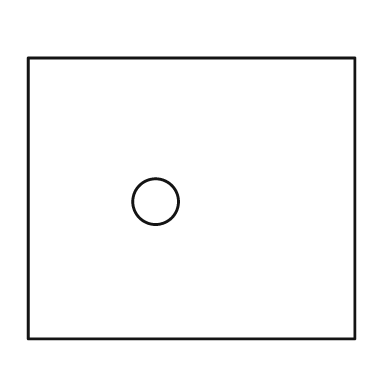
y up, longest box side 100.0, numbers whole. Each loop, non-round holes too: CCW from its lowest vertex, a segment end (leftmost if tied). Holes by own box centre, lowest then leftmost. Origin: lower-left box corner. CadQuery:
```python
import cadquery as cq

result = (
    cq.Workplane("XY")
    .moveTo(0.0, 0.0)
    .lineTo(100.0, 0.0)
    .lineTo(100.0, 86.0)
    .lineTo(0.0, 86.0)
    .close()
    .moveTo(39.0, 42.0)
    .circle(7.0)
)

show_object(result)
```